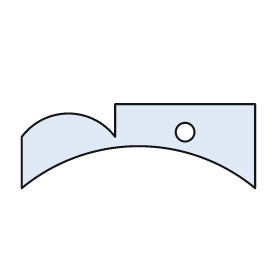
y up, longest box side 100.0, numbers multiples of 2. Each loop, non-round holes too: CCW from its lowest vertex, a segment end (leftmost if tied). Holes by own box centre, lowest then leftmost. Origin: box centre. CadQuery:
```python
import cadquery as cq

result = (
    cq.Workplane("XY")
    .moveTo(-50.0, -18.0)
    .threePointArc((0.0, 0.0), (50.0, -18.0))
    .lineTo(50.0, 18.0)
    .lineTo(-10.0, 18.0)
    .lineTo(-10.0, 4.0)
    .threePointArc((-30.0, 14.0), (-50.0, 4.0))
    .close()
    .moveTo(20.0, 6.0)
    .circle(4.0)
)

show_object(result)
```